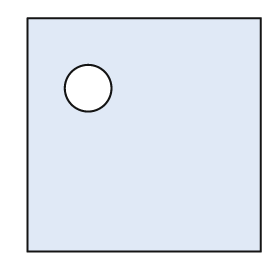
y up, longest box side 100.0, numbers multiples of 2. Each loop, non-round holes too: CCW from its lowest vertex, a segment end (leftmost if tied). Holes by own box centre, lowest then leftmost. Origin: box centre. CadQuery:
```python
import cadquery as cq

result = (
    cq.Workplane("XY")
    .moveTo(-50.0, -50.0)
    .lineTo(50.0, -50.0)
    .lineTo(50.0, 50.0)
    .lineTo(-50.0, 50.0)
    .close()
    .moveTo(-24.0, 20.0)
    .circle(10.0)
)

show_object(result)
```